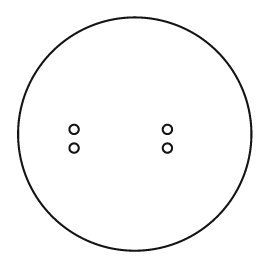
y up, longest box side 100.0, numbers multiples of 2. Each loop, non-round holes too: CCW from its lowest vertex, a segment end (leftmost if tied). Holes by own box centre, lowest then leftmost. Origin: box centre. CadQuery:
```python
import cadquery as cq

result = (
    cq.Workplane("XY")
    .moveTo(0.0, 0.0)
    .circle(50.0)
    .moveTo(-26.0, -6.0)
    .circle(2.0)
    .moveTo(14.0, -6.0)
    .circle(2.0)
    .moveTo(-26.0, 2.0)
    .circle(2.0)
    .moveTo(14.0, 2.0)
    .circle(2.0)
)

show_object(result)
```